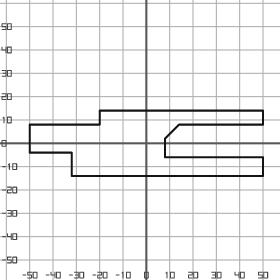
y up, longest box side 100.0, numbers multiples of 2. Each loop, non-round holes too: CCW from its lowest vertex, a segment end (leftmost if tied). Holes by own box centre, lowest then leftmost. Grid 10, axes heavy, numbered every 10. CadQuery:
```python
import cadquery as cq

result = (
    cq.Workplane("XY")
    .moveTo(-32.0, -14.0)
    .lineTo(50.0, -14.0)
    .lineTo(50.0, -6.0)
    .lineTo(8.0, -6.0)
    .lineTo(8.0, 2.0)
    .lineTo(14.0, 8.0)
    .lineTo(50.0, 8.0)
    .lineTo(50.0, 14.0)
    .lineTo(-20.0, 14.0)
    .lineTo(-20.0, 8.0)
    .lineTo(-50.0, 8.0)
    .lineTo(-50.0, -4.0)
    .lineTo(-32.0, -4.0)
    .close()
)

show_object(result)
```